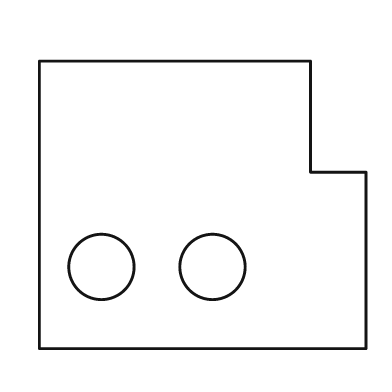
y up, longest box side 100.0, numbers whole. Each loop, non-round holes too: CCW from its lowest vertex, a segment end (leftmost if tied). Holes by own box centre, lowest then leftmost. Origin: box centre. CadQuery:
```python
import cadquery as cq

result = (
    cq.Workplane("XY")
    .moveTo(-50.0, -44.0)
    .lineTo(50.0, -44.0)
    .lineTo(50.0, 10.0)
    .lineTo(33.0, 10.0)
    .lineTo(33.0, 44.0)
    .lineTo(-50.0, 44.0)
    .close()
    .moveTo(-31.0, -19.0)
    .circle(10.0)
    .moveTo(3.0, -19.0)
    .circle(10.0)
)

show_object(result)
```